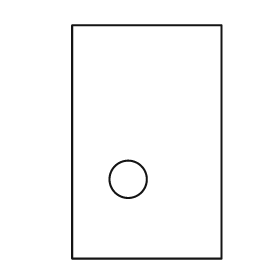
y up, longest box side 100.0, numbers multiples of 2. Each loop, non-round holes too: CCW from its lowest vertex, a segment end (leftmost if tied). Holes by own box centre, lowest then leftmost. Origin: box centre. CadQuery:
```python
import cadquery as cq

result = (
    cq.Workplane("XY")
    .moveTo(-32.0, -50.0)
    .lineTo(32.0, -50.0)
    .lineTo(32.0, 50.0)
    .lineTo(-32.0, 50.0)
    .close()
    .moveTo(-8.0, -16.0)
    .circle(8.0)
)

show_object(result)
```